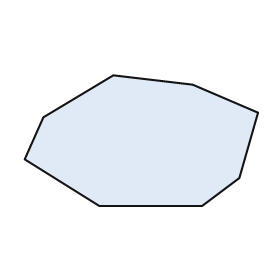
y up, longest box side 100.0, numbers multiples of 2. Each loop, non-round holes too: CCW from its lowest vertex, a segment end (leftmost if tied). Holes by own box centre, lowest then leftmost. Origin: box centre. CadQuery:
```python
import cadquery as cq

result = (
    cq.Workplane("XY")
    .moveTo(-18.0, -28.0)
    .lineTo(26.0, -28.0)
    .lineTo(42.0, -16.0)
    .lineTo(50.0, 12.0)
    .lineTo(22.0, 24.0)
    .lineTo(-12.0, 28.0)
    .lineTo(-42.0, 10.0)
    .lineTo(-50.0, -8.0)
    .close()
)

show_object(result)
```